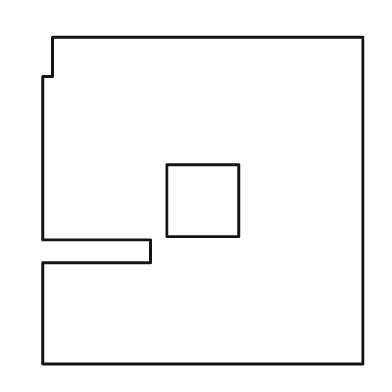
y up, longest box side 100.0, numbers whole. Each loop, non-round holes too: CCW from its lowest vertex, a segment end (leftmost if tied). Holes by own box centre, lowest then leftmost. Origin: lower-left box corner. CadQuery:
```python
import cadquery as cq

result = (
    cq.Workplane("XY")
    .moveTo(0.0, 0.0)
    .lineTo(98.0, 0.0)
    .lineTo(98.0, 100.0)
    .lineTo(3.0, 100.0)
    .lineTo(3.0, 88.0)
    .lineTo(0.0, 88.0)
    .lineTo(0.0, 38.0)
    .lineTo(33.0, 38.0)
    .lineTo(33.0, 31.0)
    .lineTo(0.0, 31.0)
    .close()
    .moveTo(38.0, 39.0)
    .lineTo(60.0, 39.0)
    .lineTo(60.0, 61.0)
    .lineTo(38.0, 61.0)
    .close()
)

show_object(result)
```